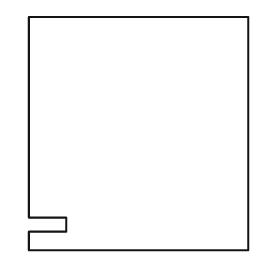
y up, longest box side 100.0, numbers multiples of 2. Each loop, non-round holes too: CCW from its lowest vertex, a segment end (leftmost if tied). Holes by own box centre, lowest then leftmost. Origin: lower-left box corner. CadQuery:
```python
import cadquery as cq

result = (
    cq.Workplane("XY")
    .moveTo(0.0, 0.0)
    .lineTo(94.0, 0.0)
    .lineTo(94.0, 100.0)
    .lineTo(0.0, 100.0)
    .lineTo(0.0, 14.0)
    .lineTo(16.0, 14.0)
    .lineTo(16.0, 8.0)
    .lineTo(0.0, 8.0)
    .close()
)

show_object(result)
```